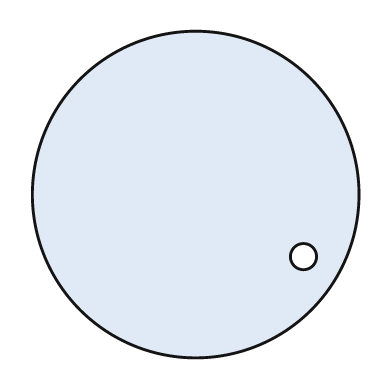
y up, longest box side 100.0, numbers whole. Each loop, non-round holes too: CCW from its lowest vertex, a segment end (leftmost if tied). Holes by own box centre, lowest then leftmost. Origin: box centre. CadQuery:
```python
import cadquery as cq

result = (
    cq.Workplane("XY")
    .moveTo(0.0, 0.0)
    .circle(50.0)
    .moveTo(33.0, -19.0)
    .circle(4.0)
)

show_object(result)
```